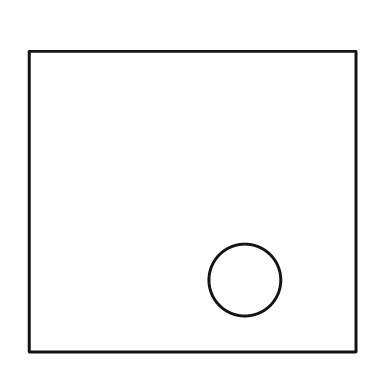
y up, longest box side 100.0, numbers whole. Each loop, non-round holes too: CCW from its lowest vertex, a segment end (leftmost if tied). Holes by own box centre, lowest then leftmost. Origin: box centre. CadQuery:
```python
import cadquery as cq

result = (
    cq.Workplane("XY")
    .moveTo(-50.0, -46.0)
    .lineTo(50.0, -46.0)
    .lineTo(50.0, 46.0)
    .lineTo(-50.0, 46.0)
    .close()
    .moveTo(16.0, -24.0)
    .circle(11.0)
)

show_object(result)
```